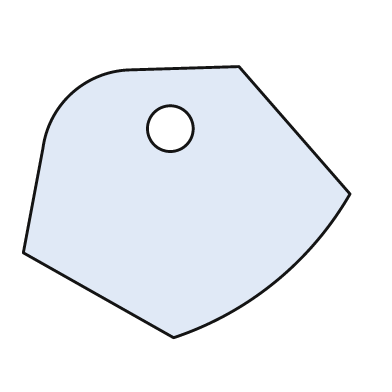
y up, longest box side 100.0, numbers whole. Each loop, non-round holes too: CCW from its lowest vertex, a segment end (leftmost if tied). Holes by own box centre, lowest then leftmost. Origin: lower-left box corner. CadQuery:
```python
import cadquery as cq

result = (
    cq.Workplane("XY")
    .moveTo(46.0, 0.0)
    .threePointArc((77.0, 17.0), (100.0, 44.0))
    .lineTo(66.0, 83.0)
    .lineTo(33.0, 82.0)
    .threePointArc((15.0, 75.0), (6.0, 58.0))
    .lineTo(0.0, 26.0)
    .close()
    .moveTo(45.0, 64.0)
    .circle(7.0)
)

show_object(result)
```